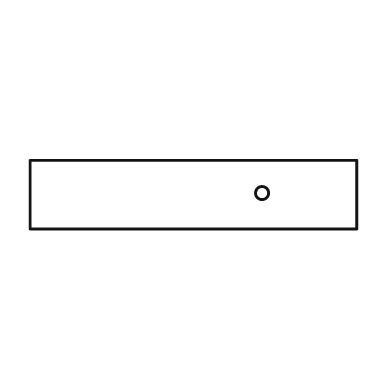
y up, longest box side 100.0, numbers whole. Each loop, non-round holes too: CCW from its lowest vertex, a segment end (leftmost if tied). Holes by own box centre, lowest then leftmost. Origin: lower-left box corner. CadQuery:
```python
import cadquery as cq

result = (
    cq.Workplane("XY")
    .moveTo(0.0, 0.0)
    .lineTo(100.0, 0.0)
    .lineTo(100.0, 21.0)
    .lineTo(0.0, 21.0)
    .close()
    .moveTo(71.0, 11.0)
    .circle(2.0)
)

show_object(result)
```